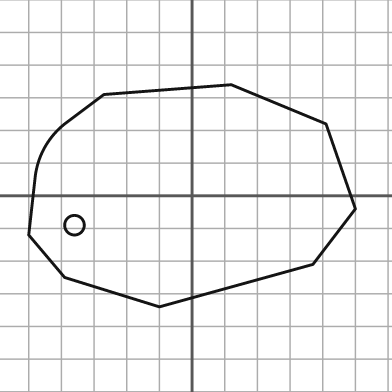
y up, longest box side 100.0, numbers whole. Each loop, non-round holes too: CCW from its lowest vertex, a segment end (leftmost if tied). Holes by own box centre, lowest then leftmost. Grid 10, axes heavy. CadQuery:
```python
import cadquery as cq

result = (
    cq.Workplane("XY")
    .moveTo(-10.0, -34.0)
    .lineTo(37.0, -21.0)
    .lineTo(50.0, -4.0)
    .lineTo(41.0, 22.0)
    .lineTo(12.0, 34.0)
    .lineTo(-27.0, 31.0)
    .lineTo(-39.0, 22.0)
    .threePointArc((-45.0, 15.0), (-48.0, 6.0))
    .lineTo(-50.0, -12.0)
    .lineTo(-39.0, -25.0)
    .close()
    .moveTo(-36.0, -9.0)
    .circle(3.0)
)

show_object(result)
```